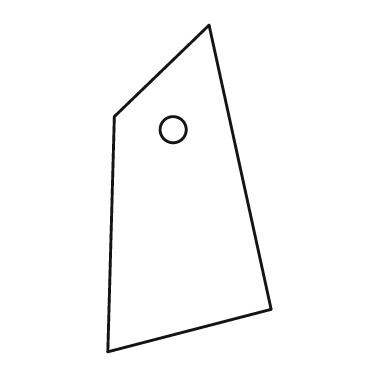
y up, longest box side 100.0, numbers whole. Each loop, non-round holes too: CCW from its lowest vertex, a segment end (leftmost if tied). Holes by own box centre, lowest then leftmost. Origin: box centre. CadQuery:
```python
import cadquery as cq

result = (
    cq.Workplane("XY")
    .moveTo(-25.0, -50.0)
    .lineTo(25.0, -37.0)
    .lineTo(6.0, 50.0)
    .lineTo(-23.0, 22.0)
    .close()
    .moveTo(-5.0, 18.0)
    .circle(4.0)
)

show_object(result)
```